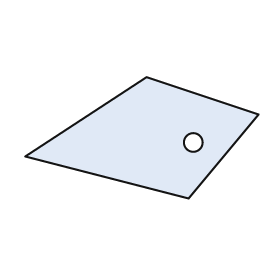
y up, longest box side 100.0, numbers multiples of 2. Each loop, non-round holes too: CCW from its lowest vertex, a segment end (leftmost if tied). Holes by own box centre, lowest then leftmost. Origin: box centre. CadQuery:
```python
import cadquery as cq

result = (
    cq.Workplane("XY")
    .moveTo(20.0, -26.0)
    .lineTo(50.0, 10.0)
    .lineTo(2.0, 26.0)
    .lineTo(-50.0, -8.0)
    .close()
    .moveTo(22.0, -2.0)
    .circle(4.0)
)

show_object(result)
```